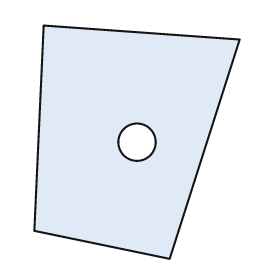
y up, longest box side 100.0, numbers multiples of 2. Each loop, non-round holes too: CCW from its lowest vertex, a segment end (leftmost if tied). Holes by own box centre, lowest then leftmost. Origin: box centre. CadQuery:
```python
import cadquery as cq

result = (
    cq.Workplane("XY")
    .moveTo(14.0, -50.0)
    .lineTo(44.0, 44.0)
    .lineTo(-40.0, 50.0)
    .lineTo(-44.0, -38.0)
    .close()
    .moveTo(0.0, 0.0)
    .circle(8.0)
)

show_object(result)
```